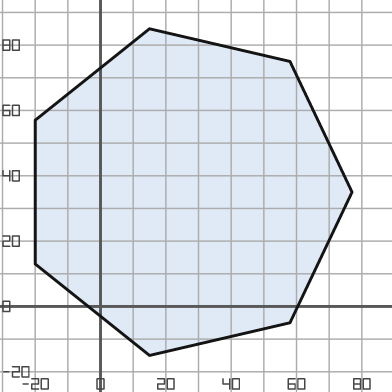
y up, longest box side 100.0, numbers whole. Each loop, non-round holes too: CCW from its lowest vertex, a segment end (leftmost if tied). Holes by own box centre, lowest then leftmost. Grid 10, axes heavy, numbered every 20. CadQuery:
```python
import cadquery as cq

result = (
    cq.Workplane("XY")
    .moveTo(15.0, -15.0)
    .lineTo(58.0, -5.0)
    .lineTo(77.0, 35.0)
    .lineTo(58.0, 75.0)
    .lineTo(15.0, 85.0)
    .lineTo(-20.0, 57.0)
    .lineTo(-20.0, 13.0)
    .close()
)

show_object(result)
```